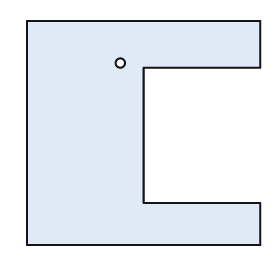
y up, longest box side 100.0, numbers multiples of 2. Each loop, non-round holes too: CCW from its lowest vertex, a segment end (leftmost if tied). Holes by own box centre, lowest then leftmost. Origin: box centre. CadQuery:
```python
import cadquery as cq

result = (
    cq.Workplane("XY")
    .moveTo(-50.0, -48.0)
    .lineTo(50.0, -48.0)
    .lineTo(50.0, -30.0)
    .lineTo(0.0, -30.0)
    .lineTo(0.0, 28.0)
    .lineTo(50.0, 28.0)
    .lineTo(50.0, 48.0)
    .lineTo(-50.0, 48.0)
    .close()
    .moveTo(-10.0, 30.0)
    .circle(2.0)
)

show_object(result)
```